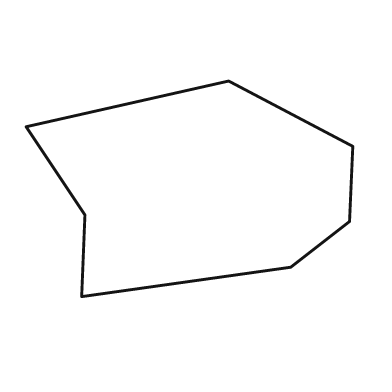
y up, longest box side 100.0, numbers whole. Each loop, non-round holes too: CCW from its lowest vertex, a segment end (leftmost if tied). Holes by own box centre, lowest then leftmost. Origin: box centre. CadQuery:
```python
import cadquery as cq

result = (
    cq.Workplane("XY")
    .moveTo(-33.0, -33.0)
    .lineTo(31.0, -24.0)
    .lineTo(49.0, -10.0)
    .lineTo(50.0, 13.0)
    .lineTo(12.0, 33.0)
    .lineTo(-50.0, 19.0)
    .lineTo(-32.0, -8.0)
    .close()
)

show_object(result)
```